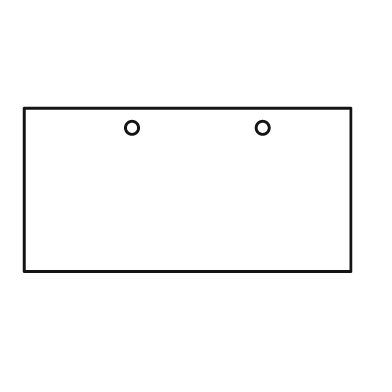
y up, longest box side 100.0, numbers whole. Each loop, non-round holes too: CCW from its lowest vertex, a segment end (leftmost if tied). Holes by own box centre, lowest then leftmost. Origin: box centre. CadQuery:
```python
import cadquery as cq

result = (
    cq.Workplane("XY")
    .moveTo(-50.0, -25.0)
    .lineTo(50.0, -25.0)
    .lineTo(50.0, 25.0)
    .lineTo(-50.0, 25.0)
    .close()
    .moveTo(-17.0, 19.0)
    .circle(2.0)
    .moveTo(23.0, 19.0)
    .circle(2.0)
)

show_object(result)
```